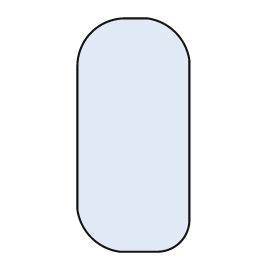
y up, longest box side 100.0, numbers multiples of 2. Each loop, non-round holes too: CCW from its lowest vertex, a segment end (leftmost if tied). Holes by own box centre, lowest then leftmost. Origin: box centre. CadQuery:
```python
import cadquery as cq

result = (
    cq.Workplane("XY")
    .moveTo(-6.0, -50.0)
    .lineTo(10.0, -50.0)
    .threePointArc((20.0, -46.0), (24.0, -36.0))
    .lineTo(24.0, 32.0)
    .threePointArc((18.0, 44.0), (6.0, 50.0))
    .lineTo(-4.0, 50.0)
    .threePointArc((-18.0, 44.0), (-24.0, 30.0))
    .lineTo(-24.0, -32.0)
    .threePointArc((-18.0, -44.0), (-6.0, -50.0))
    .close()
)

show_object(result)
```